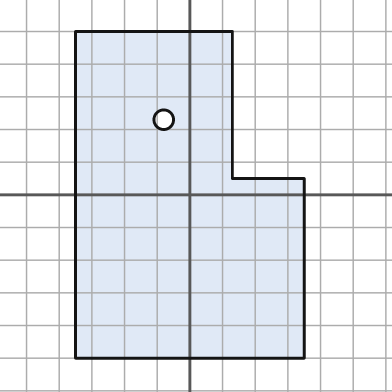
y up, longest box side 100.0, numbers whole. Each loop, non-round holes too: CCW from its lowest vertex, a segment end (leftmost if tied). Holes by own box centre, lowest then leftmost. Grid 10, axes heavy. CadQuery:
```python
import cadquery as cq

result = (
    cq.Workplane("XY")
    .moveTo(-35.0, -50.0)
    .lineTo(35.0, -50.0)
    .lineTo(35.0, 5.0)
    .lineTo(13.0, 5.0)
    .lineTo(13.0, 50.0)
    .lineTo(-35.0, 50.0)
    .close()
    .moveTo(-8.0, 23.0)
    .circle(3.0)
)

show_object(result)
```